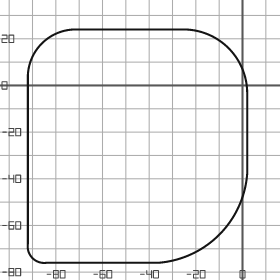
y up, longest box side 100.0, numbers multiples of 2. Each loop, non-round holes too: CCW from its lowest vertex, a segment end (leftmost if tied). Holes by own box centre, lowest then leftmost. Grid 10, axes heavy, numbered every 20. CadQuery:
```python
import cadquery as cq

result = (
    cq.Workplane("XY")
    .moveTo(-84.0, -76.0)
    .lineTo(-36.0, -76.0)
    .threePointArc((-10.0, -64.0), (2.0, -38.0))
    .lineTo(2.0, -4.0)
    .threePointArc((-6.0, 16.0), (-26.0, 24.0))
    .lineTo(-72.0, 24.0)
    .threePointArc((-86.0, 18.0), (-92.0, 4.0))
    .lineTo(-92.0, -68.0)
    .threePointArc((-90.0, -74.0), (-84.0, -76.0))
    .close()
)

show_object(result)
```